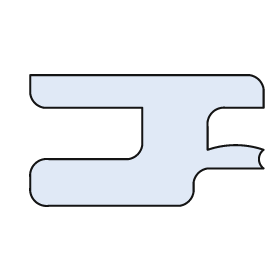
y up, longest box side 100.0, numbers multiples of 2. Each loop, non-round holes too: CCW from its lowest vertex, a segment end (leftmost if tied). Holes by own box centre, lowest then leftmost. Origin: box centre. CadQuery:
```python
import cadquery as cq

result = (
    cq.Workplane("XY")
    .moveTo(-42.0, -28.0)
    .lineTo(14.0, -28.0)
    .threePointArc((18.0, -26.0), (20.0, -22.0))
    .lineTo(20.0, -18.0)
    .threePointArc((22.0, -14.0), (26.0, -12.0))
    .lineTo(50.0, -12.0)
    .threePointArc((48.0, -8.0), (50.0, -4.0))
    .threePointArc((38.0, -2.0), (26.0, -4.0))
    .lineTo(26.0, 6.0)
    .threePointArc((28.0, 12.0), (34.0, 14.0))
    .lineTo(50.0, 14.0)
    .lineTo(50.0, 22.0)
    .threePointArc((48.0, 26.0), (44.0, 28.0))
    .lineTo(-50.0, 28.0)
    .lineTo(-50.0, 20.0)
    .threePointArc((-48.0, 16.0), (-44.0, 14.0))
    .lineTo(-2.0, 14.0)
    .lineTo(-2.0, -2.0)
    .threePointArc((-4.0, -6.0), (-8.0, -8.0))
    .lineTo(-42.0, -8.0)
    .threePointArc((-48.0, -10.0), (-50.0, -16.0))
    .lineTo(-50.0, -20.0)
    .threePointArc((-48.0, -26.0), (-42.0, -28.0))
    .close()
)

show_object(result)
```